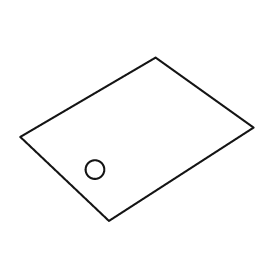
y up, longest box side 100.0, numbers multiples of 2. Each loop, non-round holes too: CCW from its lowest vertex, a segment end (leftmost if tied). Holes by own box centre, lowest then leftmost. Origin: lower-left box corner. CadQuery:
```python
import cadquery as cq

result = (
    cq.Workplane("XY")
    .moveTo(38.0, 0.0)
    .lineTo(100.0, 40.0)
    .lineTo(58.0, 70.0)
    .lineTo(0.0, 36.0)
    .close()
    .moveTo(32.0, 22.0)
    .circle(4.0)
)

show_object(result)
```